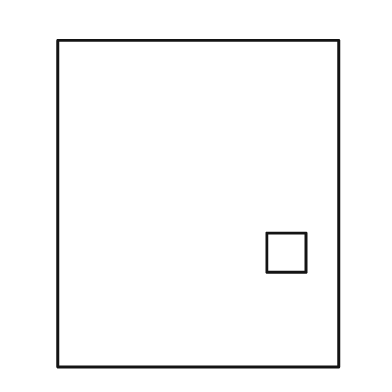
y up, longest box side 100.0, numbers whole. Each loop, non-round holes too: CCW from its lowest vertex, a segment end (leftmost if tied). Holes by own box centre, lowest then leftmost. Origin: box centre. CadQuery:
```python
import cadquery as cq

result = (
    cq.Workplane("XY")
    .moveTo(-43.0, -50.0)
    .lineTo(43.0, -50.0)
    .lineTo(43.0, 50.0)
    .lineTo(-43.0, 50.0)
    .close()
    .moveTo(21.0, -21.0)
    .lineTo(33.0, -21.0)
    .lineTo(33.0, -9.0)
    .lineTo(21.0, -9.0)
    .close()
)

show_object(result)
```